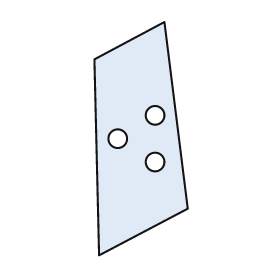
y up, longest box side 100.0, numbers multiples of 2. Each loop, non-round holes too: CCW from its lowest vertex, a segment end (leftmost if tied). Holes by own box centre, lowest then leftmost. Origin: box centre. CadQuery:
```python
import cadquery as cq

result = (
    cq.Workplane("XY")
    .moveTo(-18.0, -50.0)
    .lineTo(20.0, -30.0)
    .lineTo(10.0, 50.0)
    .lineTo(-20.0, 34.0)
    .close()
    .moveTo(6.0, -10.0)
    .circle(4.0)
    .moveTo(-10.0, 0.0)
    .circle(4.0)
    .moveTo(6.0, 10.0)
    .circle(4.0)
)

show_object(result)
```